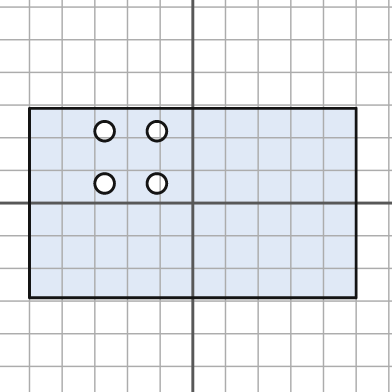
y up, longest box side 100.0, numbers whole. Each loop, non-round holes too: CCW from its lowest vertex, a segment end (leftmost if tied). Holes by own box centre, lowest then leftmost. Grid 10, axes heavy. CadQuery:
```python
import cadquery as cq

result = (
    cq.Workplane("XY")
    .moveTo(-50.0, -29.0)
    .lineTo(50.0, -29.0)
    .lineTo(50.0, 29.0)
    .lineTo(-50.0, 29.0)
    .close()
    .moveTo(-27.0, 6.0)
    .circle(3.0)
    .moveTo(-11.0, 6.0)
    .circle(3.0)
    .moveTo(-27.0, 22.0)
    .circle(3.0)
    .moveTo(-11.0, 22.0)
    .circle(3.0)
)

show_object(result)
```